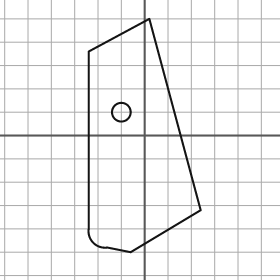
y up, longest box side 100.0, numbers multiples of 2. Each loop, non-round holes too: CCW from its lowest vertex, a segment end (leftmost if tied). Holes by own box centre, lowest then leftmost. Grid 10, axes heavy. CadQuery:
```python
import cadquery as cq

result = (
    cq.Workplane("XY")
    .moveTo(-6.0, -50.0)
    .lineTo(24.0, -32.0)
    .lineTo(2.0, 50.0)
    .lineTo(-24.0, 36.0)
    .lineTo(-24.0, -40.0)
    .threePointArc((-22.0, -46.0), (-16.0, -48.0))
    .close()
    .moveTo(-10.0, 10.0)
    .circle(4.0)
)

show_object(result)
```